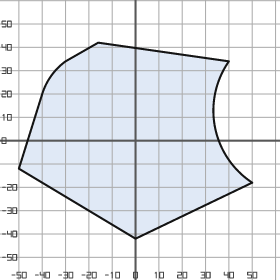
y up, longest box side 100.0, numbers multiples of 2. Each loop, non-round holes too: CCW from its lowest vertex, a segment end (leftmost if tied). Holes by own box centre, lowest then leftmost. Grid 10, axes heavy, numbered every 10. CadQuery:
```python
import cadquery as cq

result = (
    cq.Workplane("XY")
    .moveTo(0.0, -42.0)
    .lineTo(50.0, -18.0)
    .threePointArc((34.0, 6.0), (40.0, 34.0))
    .lineTo(-16.0, 42.0)
    .lineTo(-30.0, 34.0)
    .threePointArc((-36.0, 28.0), (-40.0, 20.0))
    .lineTo(-50.0, -12.0)
    .close()
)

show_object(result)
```